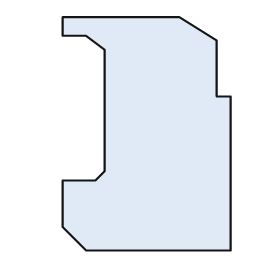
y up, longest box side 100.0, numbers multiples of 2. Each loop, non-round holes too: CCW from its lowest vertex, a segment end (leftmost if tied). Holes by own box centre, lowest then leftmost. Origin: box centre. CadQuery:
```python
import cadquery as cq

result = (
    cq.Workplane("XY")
    .moveTo(-26.0, -50.0)
    .lineTo(36.0, -50.0)
    .lineTo(36.0, 16.0)
    .lineTo(30.0, 16.0)
    .lineTo(30.0, 40.0)
    .lineTo(14.0, 50.0)
    .lineTo(-36.0, 50.0)
    .lineTo(-36.0, 42.0)
    .lineTo(-26.0, 42.0)
    .lineTo(-18.0, 36.0)
    .lineTo(-18.0, -16.0)
    .lineTo(-22.0, -20.0)
    .lineTo(-36.0, -20.0)
    .lineTo(-36.0, -40.0)
    .close()
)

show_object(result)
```